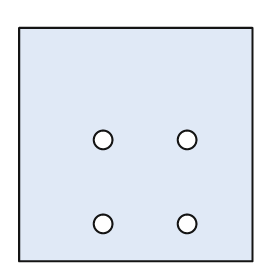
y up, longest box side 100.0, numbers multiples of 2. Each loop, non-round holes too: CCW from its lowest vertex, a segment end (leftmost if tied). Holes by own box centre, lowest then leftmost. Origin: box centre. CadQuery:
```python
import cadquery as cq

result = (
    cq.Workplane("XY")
    .moveTo(-50.0, -50.0)
    .lineTo(50.0, -50.0)
    .lineTo(50.0, 50.0)
    .lineTo(-50.0, 50.0)
    .close()
    .moveTo(-14.0, -34.0)
    .circle(4.0)
    .moveTo(22.0, -34.0)
    .circle(4.0)
    .moveTo(-14.0, 2.0)
    .circle(4.0)
    .moveTo(22.0, 2.0)
    .circle(4.0)
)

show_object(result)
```